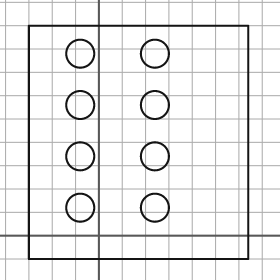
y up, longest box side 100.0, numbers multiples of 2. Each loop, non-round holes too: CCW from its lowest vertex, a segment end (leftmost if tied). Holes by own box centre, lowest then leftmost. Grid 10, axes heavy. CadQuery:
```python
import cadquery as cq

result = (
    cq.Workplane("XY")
    .moveTo(-30.0, -10.0)
    .lineTo(64.0, -10.0)
    .lineTo(64.0, 90.0)
    .lineTo(-30.0, 90.0)
    .close()
    .moveTo(-8.0, 12.0)
    .circle(6.0)
    .moveTo(24.0, 12.0)
    .circle(6.0)
    .moveTo(-8.0, 34.0)
    .circle(6.0)
    .moveTo(24.0, 34.0)
    .circle(6.0)
    .moveTo(-8.0, 56.0)
    .circle(6.0)
    .moveTo(24.0, 56.0)
    .circle(6.0)
    .moveTo(-8.0, 78.0)
    .circle(6.0)
    .moveTo(24.0, 78.0)
    .circle(6.0)
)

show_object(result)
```